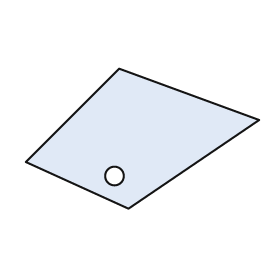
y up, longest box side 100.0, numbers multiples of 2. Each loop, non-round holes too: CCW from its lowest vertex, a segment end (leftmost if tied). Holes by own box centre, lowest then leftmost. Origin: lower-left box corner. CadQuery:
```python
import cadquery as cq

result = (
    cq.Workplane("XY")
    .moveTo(44.0, 0.0)
    .lineTo(100.0, 38.0)
    .lineTo(40.0, 60.0)
    .lineTo(0.0, 20.0)
    .close()
    .moveTo(38.0, 14.0)
    .circle(4.0)
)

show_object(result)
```